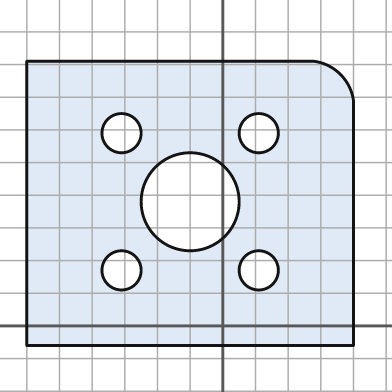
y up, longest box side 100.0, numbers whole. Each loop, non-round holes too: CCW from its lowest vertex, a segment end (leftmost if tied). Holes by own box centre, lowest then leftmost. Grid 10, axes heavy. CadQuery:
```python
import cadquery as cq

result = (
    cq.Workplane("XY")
    .moveTo(-60.0, -6.0)
    .lineTo(40.0, -6.0)
    .lineTo(40.0, 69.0)
    .threePointArc((36.0, 77.0), (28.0, 81.0))
    .lineTo(-60.0, 81.0)
    .close()
    .moveTo(-31.0, 17.0)
    .circle(6.0)
    .moveTo(11.0, 17.0)
    .circle(6.0)
    .moveTo(-10.0, 38.0)
    .circle(15.0)
    .moveTo(-31.0, 59.0)
    .circle(6.0)
    .moveTo(11.0, 59.0)
    .circle(6.0)
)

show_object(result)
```